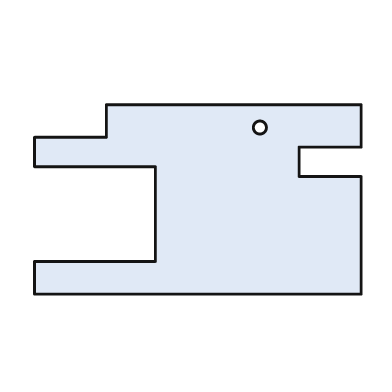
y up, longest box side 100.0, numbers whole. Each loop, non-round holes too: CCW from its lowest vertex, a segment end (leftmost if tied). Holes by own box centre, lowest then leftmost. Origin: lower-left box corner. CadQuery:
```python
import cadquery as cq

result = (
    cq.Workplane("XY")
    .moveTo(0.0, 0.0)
    .lineTo(100.0, 0.0)
    .lineTo(100.0, 36.0)
    .lineTo(81.0, 36.0)
    .lineTo(81.0, 45.0)
    .lineTo(100.0, 45.0)
    .lineTo(100.0, 58.0)
    .lineTo(22.0, 58.0)
    .lineTo(22.0, 48.0)
    .lineTo(0.0, 48.0)
    .lineTo(0.0, 39.0)
    .lineTo(37.0, 39.0)
    .lineTo(37.0, 10.0)
    .lineTo(0.0, 10.0)
    .close()
    .moveTo(69.0, 51.0)
    .circle(2.0)
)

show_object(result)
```